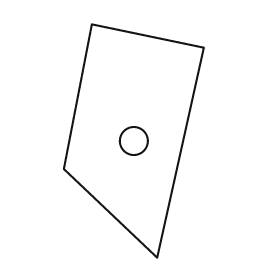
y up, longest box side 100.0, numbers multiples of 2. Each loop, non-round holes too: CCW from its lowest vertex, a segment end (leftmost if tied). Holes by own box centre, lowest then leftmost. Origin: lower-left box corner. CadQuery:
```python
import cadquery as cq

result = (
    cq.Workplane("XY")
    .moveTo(40.0, 0.0)
    .lineTo(60.0, 90.0)
    .lineTo(12.0, 100.0)
    .lineTo(0.0, 38.0)
    .close()
    .moveTo(30.0, 50.0)
    .circle(6.0)
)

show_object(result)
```